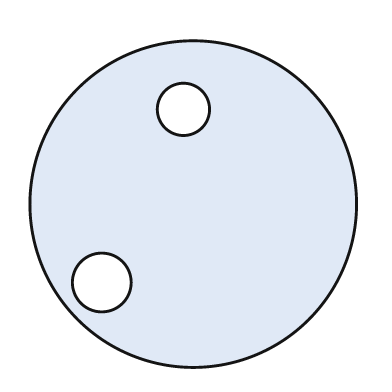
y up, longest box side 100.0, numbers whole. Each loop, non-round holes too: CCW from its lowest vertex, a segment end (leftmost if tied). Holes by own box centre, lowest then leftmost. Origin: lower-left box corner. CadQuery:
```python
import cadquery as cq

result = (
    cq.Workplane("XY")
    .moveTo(50.0, 50.0)
    .circle(50.0)
    .moveTo(22.0, 26.0)
    .circle(9.0)
    .moveTo(47.0, 79.0)
    .circle(8.0)
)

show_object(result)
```